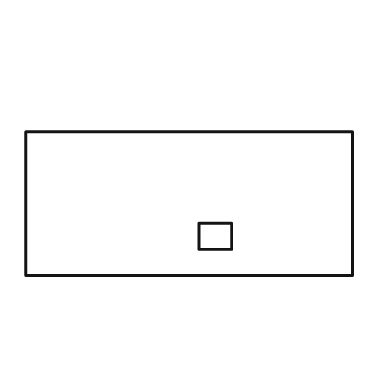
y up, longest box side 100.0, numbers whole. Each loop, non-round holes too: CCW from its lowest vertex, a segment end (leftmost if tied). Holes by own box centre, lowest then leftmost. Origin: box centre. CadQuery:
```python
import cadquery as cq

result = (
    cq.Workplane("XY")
    .moveTo(-50.0, -22.0)
    .lineTo(50.0, -22.0)
    .lineTo(50.0, 22.0)
    .lineTo(-50.0, 22.0)
    .close()
    .moveTo(3.0, -14.0)
    .lineTo(13.0, -14.0)
    .lineTo(13.0, -6.0)
    .lineTo(3.0, -6.0)
    .close()
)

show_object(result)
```